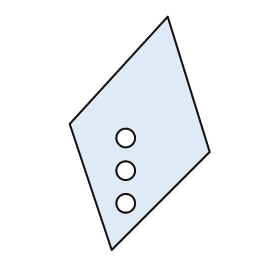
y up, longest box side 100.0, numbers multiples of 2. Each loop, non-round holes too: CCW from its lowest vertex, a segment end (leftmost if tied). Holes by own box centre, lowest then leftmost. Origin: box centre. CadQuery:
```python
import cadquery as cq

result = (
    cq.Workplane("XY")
    .moveTo(-12.0, -50.0)
    .lineTo(30.0, -8.0)
    .lineTo(12.0, 50.0)
    .lineTo(-30.0, 4.0)
    .close()
    .moveTo(-6.0, -30.0)
    .circle(4.0)
    .moveTo(-6.0, -16.0)
    .circle(4.0)
    .moveTo(-6.0, -2.0)
    .circle(4.0)
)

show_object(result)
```